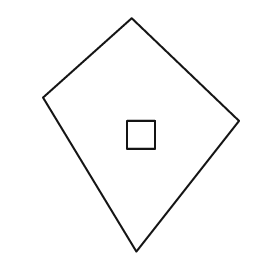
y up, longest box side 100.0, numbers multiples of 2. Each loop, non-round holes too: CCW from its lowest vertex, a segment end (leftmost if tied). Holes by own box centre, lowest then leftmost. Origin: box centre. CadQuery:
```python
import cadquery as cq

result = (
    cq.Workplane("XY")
    .moveTo(-2.0, -50.0)
    .lineTo(42.0, 6.0)
    .lineTo(-4.0, 50.0)
    .lineTo(-42.0, 16.0)
    .close()
    .moveTo(-6.0, -6.0)
    .lineTo(6.0, -6.0)
    .lineTo(6.0, 6.0)
    .lineTo(-6.0, 6.0)
    .close()
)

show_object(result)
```